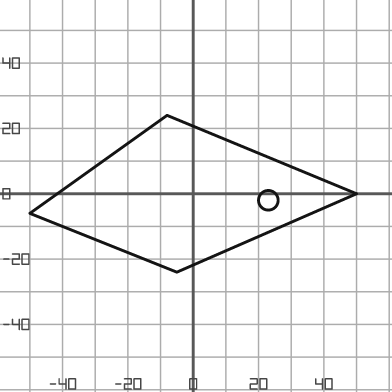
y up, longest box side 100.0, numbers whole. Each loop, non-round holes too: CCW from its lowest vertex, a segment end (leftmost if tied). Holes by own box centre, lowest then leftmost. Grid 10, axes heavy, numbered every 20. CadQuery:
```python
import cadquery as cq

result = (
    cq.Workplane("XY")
    .moveTo(-5.0, -24.0)
    .lineTo(50.0, 0.0)
    .lineTo(-8.0, 24.0)
    .lineTo(-50.0, -6.0)
    .close()
    .moveTo(23.0, -2.0)
    .circle(3.0)
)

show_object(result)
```